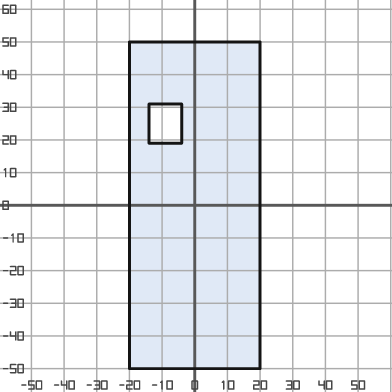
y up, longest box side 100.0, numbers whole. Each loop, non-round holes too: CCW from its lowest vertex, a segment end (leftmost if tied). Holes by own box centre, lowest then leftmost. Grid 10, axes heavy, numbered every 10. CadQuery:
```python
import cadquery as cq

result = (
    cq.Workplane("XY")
    .moveTo(-20.0, -50.0)
    .lineTo(20.0, -50.0)
    .lineTo(20.0, 50.0)
    .lineTo(-20.0, 50.0)
    .close()
    .moveTo(-14.0, 19.0)
    .lineTo(-4.0, 19.0)
    .lineTo(-4.0, 31.0)
    .lineTo(-14.0, 31.0)
    .close()
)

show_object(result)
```